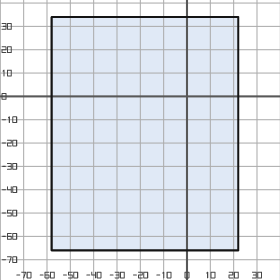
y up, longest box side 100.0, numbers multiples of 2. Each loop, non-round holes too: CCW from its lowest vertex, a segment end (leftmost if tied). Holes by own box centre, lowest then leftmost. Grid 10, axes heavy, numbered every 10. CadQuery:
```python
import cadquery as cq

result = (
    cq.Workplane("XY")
    .moveTo(-58.0, -66.0)
    .lineTo(22.0, -66.0)
    .lineTo(22.0, 34.0)
    .lineTo(-58.0, 34.0)
    .close()
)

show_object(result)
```